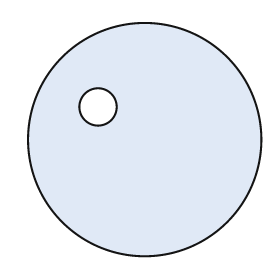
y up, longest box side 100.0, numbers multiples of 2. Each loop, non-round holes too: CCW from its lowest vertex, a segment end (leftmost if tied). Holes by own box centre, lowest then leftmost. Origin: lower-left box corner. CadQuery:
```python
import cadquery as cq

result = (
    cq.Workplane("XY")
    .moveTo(50.0, 50.0)
    .circle(50.0)
    .moveTo(30.0, 64.0)
    .circle(8.0)
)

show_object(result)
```